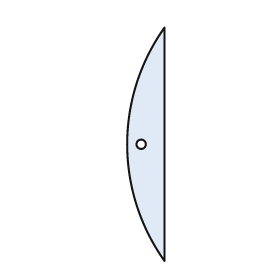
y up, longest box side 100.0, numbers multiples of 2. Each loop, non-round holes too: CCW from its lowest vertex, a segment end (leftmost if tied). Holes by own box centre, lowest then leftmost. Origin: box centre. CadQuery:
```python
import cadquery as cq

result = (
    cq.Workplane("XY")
    .moveTo(8.0, -50.0)
    .lineTo(8.0, 50.0)
    .threePointArc((-8.0, 0.0), (8.0, -50.0))
    .close()
    .moveTo(-2.0, 0.0)
    .circle(2.0)
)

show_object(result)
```